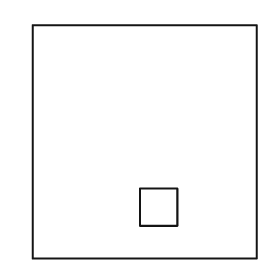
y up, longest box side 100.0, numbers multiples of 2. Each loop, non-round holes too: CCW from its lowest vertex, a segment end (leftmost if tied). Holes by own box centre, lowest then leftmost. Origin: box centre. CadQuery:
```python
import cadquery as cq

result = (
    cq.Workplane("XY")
    .moveTo(-48.0, -50.0)
    .lineTo(48.0, -50.0)
    .lineTo(48.0, 50.0)
    .lineTo(-48.0, 50.0)
    .close()
    .moveTo(-2.0, -36.0)
    .lineTo(14.0, -36.0)
    .lineTo(14.0, -20.0)
    .lineTo(-2.0, -20.0)
    .close()
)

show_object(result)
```